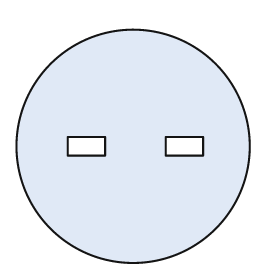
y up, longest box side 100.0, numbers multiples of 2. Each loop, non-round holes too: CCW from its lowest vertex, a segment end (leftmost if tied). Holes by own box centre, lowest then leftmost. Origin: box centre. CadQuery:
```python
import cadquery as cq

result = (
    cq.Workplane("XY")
    .moveTo(0.0, 0.0)
    .circle(50.0)
    .moveTo(-28.0, -4.0)
    .lineTo(-12.0, -4.0)
    .lineTo(-12.0, 4.0)
    .lineTo(-28.0, 4.0)
    .close()
    .moveTo(14.0, -4.0)
    .lineTo(30.0, -4.0)
    .lineTo(30.0, 4.0)
    .lineTo(14.0, 4.0)
    .close()
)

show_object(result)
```